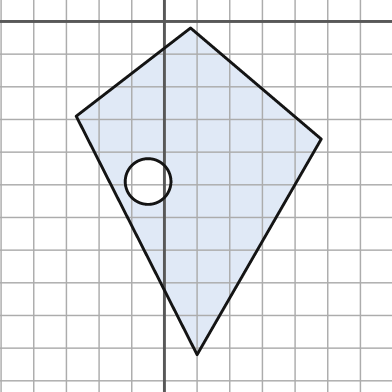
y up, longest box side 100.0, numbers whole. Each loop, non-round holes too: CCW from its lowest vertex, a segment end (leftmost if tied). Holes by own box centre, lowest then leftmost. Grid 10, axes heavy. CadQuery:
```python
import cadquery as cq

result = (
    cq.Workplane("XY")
    .moveTo(10.0, -102.0)
    .lineTo(48.0, -36.0)
    .lineTo(8.0, -2.0)
    .lineTo(-27.0, -29.0)
    .close()
    .moveTo(-5.0, -49.0)
    .circle(7.0)
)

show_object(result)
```